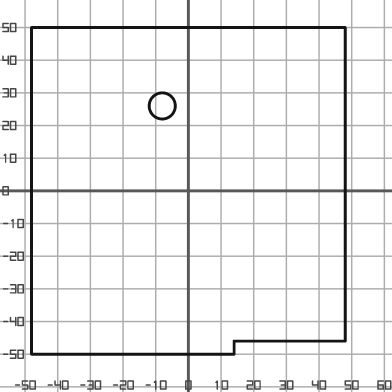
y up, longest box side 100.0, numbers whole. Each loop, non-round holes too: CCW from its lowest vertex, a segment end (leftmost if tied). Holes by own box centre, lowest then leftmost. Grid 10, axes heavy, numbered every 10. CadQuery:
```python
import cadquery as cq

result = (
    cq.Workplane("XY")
    .moveTo(-48.0, -50.0)
    .lineTo(14.0, -50.0)
    .lineTo(14.0, -46.0)
    .lineTo(48.0, -46.0)
    .lineTo(48.0, 50.0)
    .lineTo(-48.0, 50.0)
    .close()
    .moveTo(-8.0, 26.0)
    .circle(4.0)
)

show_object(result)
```